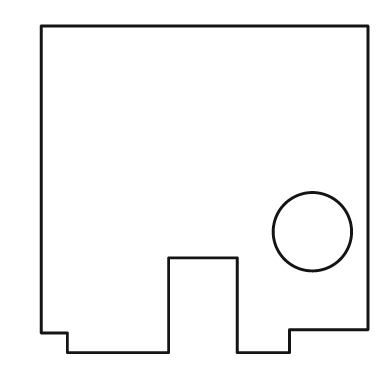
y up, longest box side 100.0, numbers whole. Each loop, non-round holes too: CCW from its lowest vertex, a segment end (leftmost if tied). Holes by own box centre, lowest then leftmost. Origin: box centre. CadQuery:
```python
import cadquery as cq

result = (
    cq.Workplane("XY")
    .moveTo(-42.0, -50.0)
    .lineTo(-11.0, -50.0)
    .lineTo(-11.0, -21.0)
    .lineTo(10.0, -21.0)
    .lineTo(10.0, -50.0)
    .lineTo(26.0, -50.0)
    .lineTo(26.0, -43.0)
    .lineTo(50.0, -43.0)
    .lineTo(50.0, 50.0)
    .lineTo(-50.0, 50.0)
    .lineTo(-50.0, -44.0)
    .lineTo(-42.0, -44.0)
    .close()
    .moveTo(33.0, -13.0)
    .circle(12.0)
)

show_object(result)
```